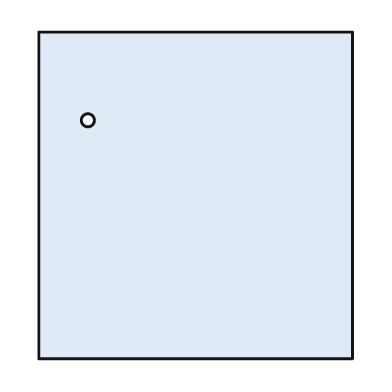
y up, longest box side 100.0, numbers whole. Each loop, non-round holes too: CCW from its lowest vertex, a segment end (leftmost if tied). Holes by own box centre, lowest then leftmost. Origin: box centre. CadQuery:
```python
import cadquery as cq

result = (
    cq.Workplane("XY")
    .moveTo(-48.0, -50.0)
    .lineTo(48.0, -50.0)
    .lineTo(48.0, 50.0)
    .lineTo(-48.0, 50.0)
    .close()
    .moveTo(-33.0, 23.0)
    .circle(2.0)
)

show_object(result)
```